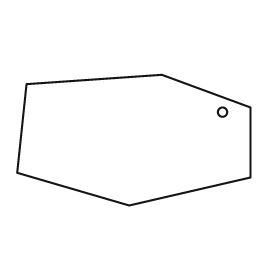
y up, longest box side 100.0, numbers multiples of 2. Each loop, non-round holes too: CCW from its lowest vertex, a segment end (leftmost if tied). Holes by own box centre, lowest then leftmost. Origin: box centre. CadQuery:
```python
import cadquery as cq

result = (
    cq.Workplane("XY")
    .moveTo(-2.0, -28.0)
    .lineTo(50.0, -16.0)
    .lineTo(50.0, 14.0)
    .lineTo(12.0, 28.0)
    .lineTo(-46.0, 24.0)
    .lineTo(-50.0, -14.0)
    .close()
    .moveTo(38.0, 12.0)
    .circle(2.0)
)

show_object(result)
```